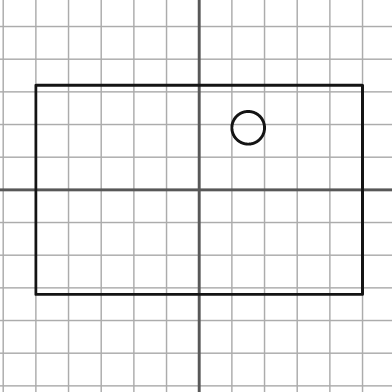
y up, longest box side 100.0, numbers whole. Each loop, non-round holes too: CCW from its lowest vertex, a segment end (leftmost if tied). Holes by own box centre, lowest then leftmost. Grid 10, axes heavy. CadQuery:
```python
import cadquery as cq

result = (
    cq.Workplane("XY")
    .moveTo(-50.0, -32.0)
    .lineTo(50.0, -32.0)
    .lineTo(50.0, 32.0)
    .lineTo(-50.0, 32.0)
    .close()
    .moveTo(15.0, 19.0)
    .circle(5.0)
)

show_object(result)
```